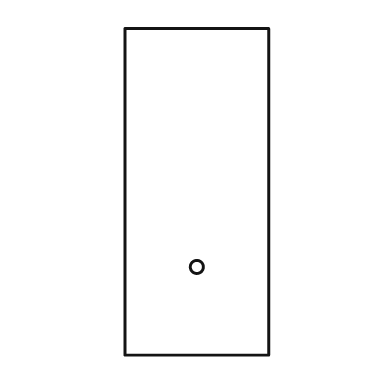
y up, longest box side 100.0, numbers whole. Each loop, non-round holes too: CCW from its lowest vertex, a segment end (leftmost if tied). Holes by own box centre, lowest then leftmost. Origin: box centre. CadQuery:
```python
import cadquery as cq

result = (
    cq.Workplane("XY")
    .moveTo(-22.0, -50.0)
    .lineTo(22.0, -50.0)
    .lineTo(22.0, 50.0)
    .lineTo(-22.0, 50.0)
    .close()
    .moveTo(0.0, -23.0)
    .circle(2.0)
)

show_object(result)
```